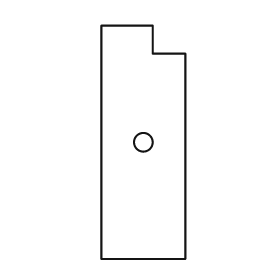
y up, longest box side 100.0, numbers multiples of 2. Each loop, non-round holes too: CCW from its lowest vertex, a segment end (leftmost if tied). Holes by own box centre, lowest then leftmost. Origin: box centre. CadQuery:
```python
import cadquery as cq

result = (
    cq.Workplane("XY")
    .moveTo(-18.0, -50.0)
    .lineTo(18.0, -50.0)
    .lineTo(18.0, 38.0)
    .lineTo(4.0, 38.0)
    .lineTo(4.0, 50.0)
    .lineTo(-18.0, 50.0)
    .close()
    .moveTo(0.0, 0.0)
    .circle(4.0)
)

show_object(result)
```